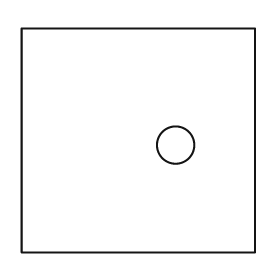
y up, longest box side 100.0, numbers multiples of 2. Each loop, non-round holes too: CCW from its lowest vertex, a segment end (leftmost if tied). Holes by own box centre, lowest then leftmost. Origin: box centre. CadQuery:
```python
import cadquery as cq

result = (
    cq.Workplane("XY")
    .moveTo(-50.0, -48.0)
    .lineTo(50.0, -48.0)
    .lineTo(50.0, 48.0)
    .lineTo(-50.0, 48.0)
    .close()
    .moveTo(16.0, -2.0)
    .circle(8.0)
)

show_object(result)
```